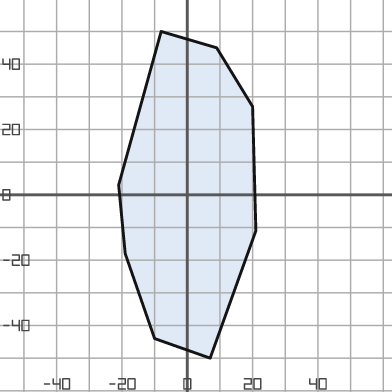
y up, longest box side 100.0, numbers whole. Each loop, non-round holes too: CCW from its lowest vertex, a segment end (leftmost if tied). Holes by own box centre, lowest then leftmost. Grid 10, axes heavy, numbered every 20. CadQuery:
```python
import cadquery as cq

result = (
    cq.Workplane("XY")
    .moveTo(7.0, -50.0)
    .lineTo(21.0, -11.0)
    .lineTo(20.0, 27.0)
    .lineTo(9.0, 45.0)
    .lineTo(-8.0, 50.0)
    .lineTo(-21.0, 3.0)
    .lineTo(-19.0, -18.0)
    .lineTo(-10.0, -44.0)
    .close()
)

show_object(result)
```